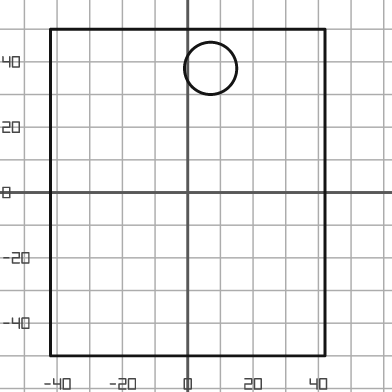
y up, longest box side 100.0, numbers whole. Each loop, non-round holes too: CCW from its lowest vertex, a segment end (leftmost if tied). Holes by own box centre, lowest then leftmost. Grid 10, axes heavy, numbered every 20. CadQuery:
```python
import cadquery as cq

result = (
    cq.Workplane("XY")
    .moveTo(-42.0, -50.0)
    .lineTo(42.0, -50.0)
    .lineTo(42.0, 50.0)
    .lineTo(-42.0, 50.0)
    .close()
    .moveTo(7.0, 38.0)
    .circle(8.0)
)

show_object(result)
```